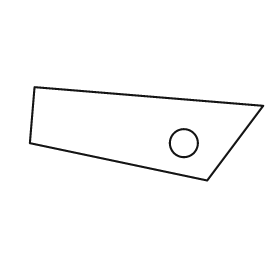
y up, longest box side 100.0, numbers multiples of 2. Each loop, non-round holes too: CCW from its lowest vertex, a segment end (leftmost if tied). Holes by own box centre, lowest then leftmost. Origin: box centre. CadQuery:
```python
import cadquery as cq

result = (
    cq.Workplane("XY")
    .moveTo(26.0, -20.0)
    .lineTo(50.0, 12.0)
    .lineTo(-48.0, 20.0)
    .lineTo(-50.0, -4.0)
    .close()
    .moveTo(16.0, -4.0)
    .circle(6.0)
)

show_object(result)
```